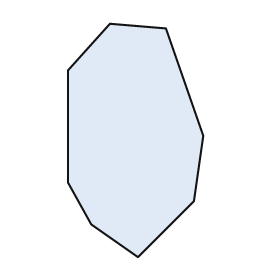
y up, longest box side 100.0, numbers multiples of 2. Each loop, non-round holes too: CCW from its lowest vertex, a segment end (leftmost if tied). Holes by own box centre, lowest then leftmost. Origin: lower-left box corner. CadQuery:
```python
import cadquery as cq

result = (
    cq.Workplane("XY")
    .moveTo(30.0, 0.0)
    .lineTo(54.0, 24.0)
    .lineTo(58.0, 52.0)
    .lineTo(42.0, 98.0)
    .lineTo(18.0, 100.0)
    .lineTo(0.0, 80.0)
    .lineTo(0.0, 32.0)
    .lineTo(10.0, 14.0)
    .close()
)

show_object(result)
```